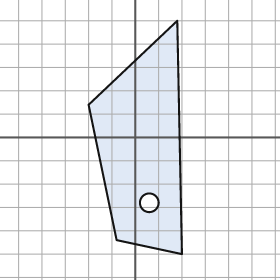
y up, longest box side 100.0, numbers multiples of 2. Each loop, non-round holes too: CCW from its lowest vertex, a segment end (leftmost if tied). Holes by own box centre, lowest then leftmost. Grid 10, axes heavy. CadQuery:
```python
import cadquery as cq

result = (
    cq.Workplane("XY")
    .moveTo(20.0, -50.0)
    .lineTo(18.0, 50.0)
    .lineTo(-20.0, 14.0)
    .lineTo(-8.0, -44.0)
    .close()
    .moveTo(6.0, -28.0)
    .circle(4.0)
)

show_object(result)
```